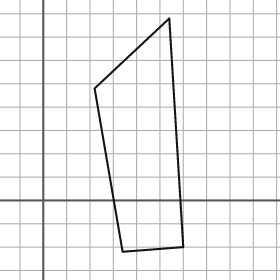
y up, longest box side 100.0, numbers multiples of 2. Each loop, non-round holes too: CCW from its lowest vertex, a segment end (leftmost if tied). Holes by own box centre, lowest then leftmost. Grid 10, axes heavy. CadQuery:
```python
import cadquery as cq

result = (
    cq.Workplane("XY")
    .moveTo(34.0, -22.0)
    .lineTo(60.0, -20.0)
    .lineTo(54.0, 78.0)
    .lineTo(22.0, 48.0)
    .close()
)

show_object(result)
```